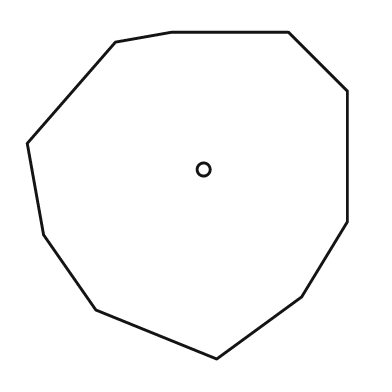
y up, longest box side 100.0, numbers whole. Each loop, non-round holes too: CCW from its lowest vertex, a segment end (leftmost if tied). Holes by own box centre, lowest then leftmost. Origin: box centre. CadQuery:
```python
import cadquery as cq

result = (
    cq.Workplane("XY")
    .moveTo(9.0, -50.0)
    .lineTo(35.0, -31.0)
    .lineTo(49.0, -8.0)
    .lineTo(49.0, 32.0)
    .lineTo(31.0, 50.0)
    .lineTo(-5.0, 50.0)
    .lineTo(-22.0, 47.0)
    .lineTo(-49.0, 16.0)
    .lineTo(-44.0, -12.0)
    .lineTo(-28.0, -35.0)
    .close()
    .moveTo(5.0, 8.0)
    .circle(2.0)
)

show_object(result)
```